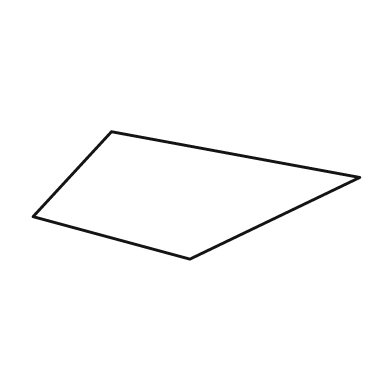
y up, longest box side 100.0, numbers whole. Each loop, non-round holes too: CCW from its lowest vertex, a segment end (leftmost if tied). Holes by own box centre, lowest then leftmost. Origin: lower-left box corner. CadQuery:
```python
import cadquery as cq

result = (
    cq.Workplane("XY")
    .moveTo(48.0, 0.0)
    .lineTo(100.0, 25.0)
    .lineTo(24.0, 39.0)
    .lineTo(0.0, 13.0)
    .close()
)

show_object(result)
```